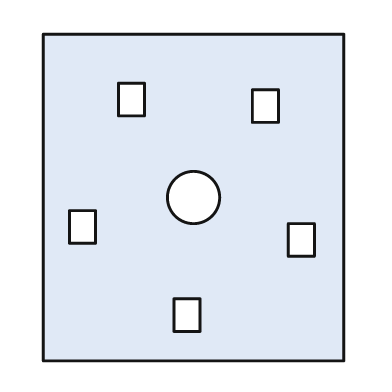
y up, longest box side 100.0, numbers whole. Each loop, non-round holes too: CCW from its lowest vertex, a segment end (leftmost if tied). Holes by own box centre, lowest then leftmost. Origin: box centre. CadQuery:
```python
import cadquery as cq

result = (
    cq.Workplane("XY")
    .moveTo(-46.0, -50.0)
    .lineTo(46.0, -50.0)
    .lineTo(46.0, 50.0)
    .lineTo(-46.0, 50.0)
    .close()
    .moveTo(-6.0, -41.0)
    .lineTo(2.0, -41.0)
    .lineTo(2.0, -31.0)
    .lineTo(-6.0, -31.0)
    .close()
    .moveTo(29.0, -18.0)
    .lineTo(37.0, -18.0)
    .lineTo(37.0, -8.0)
    .lineTo(29.0, -8.0)
    .close()
    .moveTo(-38.0, -14.0)
    .lineTo(-30.0, -14.0)
    .lineTo(-30.0, -4.0)
    .lineTo(-38.0, -4.0)
    .close()
    .moveTo(0.0, 0.0)
    .circle(8.0)
    .moveTo(18.0, 23.0)
    .lineTo(26.0, 23.0)
    .lineTo(26.0, 33.0)
    .lineTo(18.0, 33.0)
    .close()
    .moveTo(-23.0, 25.0)
    .lineTo(-15.0, 25.0)
    .lineTo(-15.0, 35.0)
    .lineTo(-23.0, 35.0)
    .close()
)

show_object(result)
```